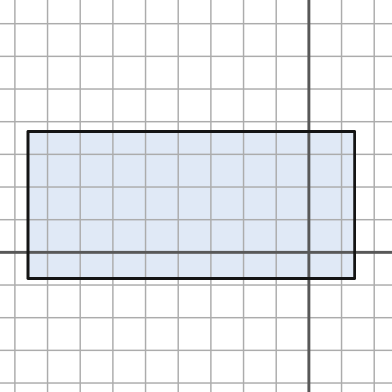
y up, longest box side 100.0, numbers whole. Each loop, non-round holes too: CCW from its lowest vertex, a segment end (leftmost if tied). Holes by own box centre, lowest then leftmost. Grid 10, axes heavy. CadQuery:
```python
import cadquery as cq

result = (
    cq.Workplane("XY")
    .moveTo(-86.0, -8.0)
    .lineTo(14.0, -8.0)
    .lineTo(14.0, 37.0)
    .lineTo(-86.0, 37.0)
    .close()
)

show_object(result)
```